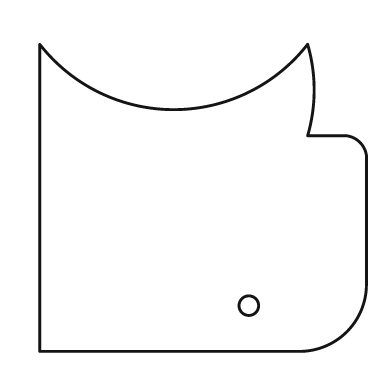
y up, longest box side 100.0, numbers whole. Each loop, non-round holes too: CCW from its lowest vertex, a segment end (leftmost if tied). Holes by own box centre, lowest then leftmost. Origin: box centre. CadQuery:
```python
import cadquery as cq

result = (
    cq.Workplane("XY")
    .moveTo(-50.0, -47.0)
    .lineTo(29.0, -47.0)
    .threePointArc((44.0, -41.0), (50.0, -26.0))
    .lineTo(50.0, 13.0)
    .threePointArc((48.0, 17.0), (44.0, 19.0))
    .lineTo(32.0, 19.0)
    .threePointArc((34.0, 33.0), (32.0, 47.0))
    .threePointArc((-9.0, 27.0), (-50.0, 47.0))
    .close()
    .moveTo(14.0, -33.0)
    .circle(3.0)
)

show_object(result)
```